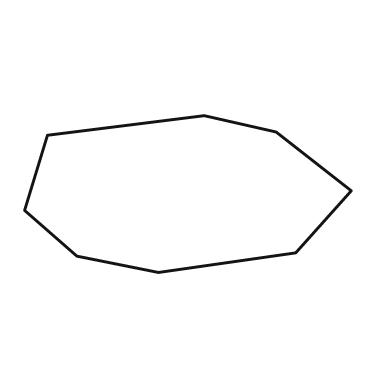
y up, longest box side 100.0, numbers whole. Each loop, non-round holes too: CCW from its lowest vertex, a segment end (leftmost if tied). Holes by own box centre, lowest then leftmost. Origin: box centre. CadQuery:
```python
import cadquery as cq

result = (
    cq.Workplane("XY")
    .moveTo(-9.0, -24.0)
    .lineTo(33.0, -18.0)
    .lineTo(50.0, 1.0)
    .lineTo(27.0, 19.0)
    .lineTo(5.0, 24.0)
    .lineTo(-43.0, 18.0)
    .lineTo(-50.0, -5.0)
    .lineTo(-34.0, -19.0)
    .close()
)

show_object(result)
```